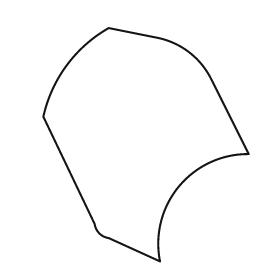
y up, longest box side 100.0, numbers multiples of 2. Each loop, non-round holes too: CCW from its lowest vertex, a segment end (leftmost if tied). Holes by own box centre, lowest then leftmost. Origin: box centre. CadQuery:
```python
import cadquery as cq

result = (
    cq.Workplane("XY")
    .moveTo(6.0, -50.0)
    .threePointArc((14.0, -18.0), (44.0, -4.0))
    .lineTo(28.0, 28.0)
    .threePointArc((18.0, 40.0), (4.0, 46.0))
    .lineTo(-16.0, 50.0)
    .threePointArc((-34.0, 34.0), (-44.0, 12.0))
    .lineTo(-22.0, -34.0)
    .threePointArc((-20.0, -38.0), (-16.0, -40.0))
    .close()
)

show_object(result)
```